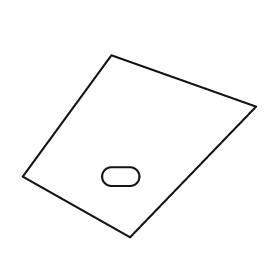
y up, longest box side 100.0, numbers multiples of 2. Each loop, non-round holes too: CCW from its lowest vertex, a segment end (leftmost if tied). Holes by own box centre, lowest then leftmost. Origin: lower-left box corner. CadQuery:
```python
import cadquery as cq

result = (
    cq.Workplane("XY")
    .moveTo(46.0, 0.0)
    .lineTo(100.0, 56.0)
    .lineTo(38.0, 78.0)
    .lineTo(0.0, 26.0)
    .close()
    .moveTo(38.0, 22.0)
    .lineTo(46.0, 22.0)
    .threePointArc((50.0, 26.0), (46.0, 30.0))
    .lineTo(38.0, 30.0)
    .threePointArc((34.0, 26.0), (38.0, 22.0))
    .close()
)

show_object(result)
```